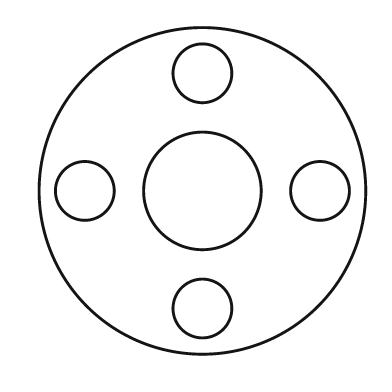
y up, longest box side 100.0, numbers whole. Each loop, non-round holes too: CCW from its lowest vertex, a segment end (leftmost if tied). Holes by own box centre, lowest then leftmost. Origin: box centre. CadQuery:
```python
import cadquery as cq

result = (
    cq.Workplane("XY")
    .moveTo(0.0, 0.0)
    .circle(50.0)
    .moveTo(0.0, -36.0)
    .circle(9.0)
    .moveTo(-36.0, 0.0)
    .circle(9.0)
    .moveTo(0.0, 0.0)
    .circle(18.0)
    .moveTo(36.0, 0.0)
    .circle(9.0)
    .moveTo(0.0, 36.0)
    .circle(9.0)
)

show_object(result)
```